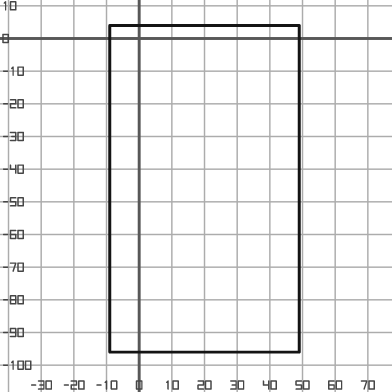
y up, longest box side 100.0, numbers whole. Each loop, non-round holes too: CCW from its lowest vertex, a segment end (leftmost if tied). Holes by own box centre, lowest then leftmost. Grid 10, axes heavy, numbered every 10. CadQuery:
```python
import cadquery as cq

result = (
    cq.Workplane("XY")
    .moveTo(-9.0, -96.0)
    .lineTo(49.0, -96.0)
    .lineTo(49.0, 4.0)
    .lineTo(-9.0, 4.0)
    .close()
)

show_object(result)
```